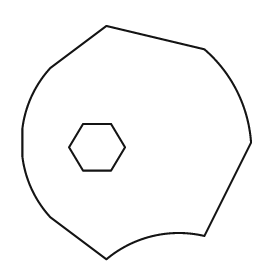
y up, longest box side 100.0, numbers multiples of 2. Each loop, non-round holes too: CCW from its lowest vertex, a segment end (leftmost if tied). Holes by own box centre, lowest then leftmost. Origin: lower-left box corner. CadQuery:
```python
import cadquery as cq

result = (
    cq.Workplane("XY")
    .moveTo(36.0, 0.0)
    .threePointArc((56.0, 10.0), (78.0, 10.0))
    .lineTo(98.0, 50.0)
    .threePointArc((92.0, 72.0), (78.0, 90.0))
    .lineTo(36.0, 100.0)
    .lineTo(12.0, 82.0)
    .threePointArc((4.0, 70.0), (0.0, 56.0))
    .lineTo(0.0, 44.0)
    .threePointArc((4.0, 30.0), (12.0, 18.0))
    .close()
    .moveTo(26.0, 38.0)
    .lineTo(38.0, 38.0)
    .lineTo(44.0, 48.0)
    .lineTo(38.0, 58.0)
    .lineTo(26.0, 58.0)
    .lineTo(20.0, 48.0)
    .close()
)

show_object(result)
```